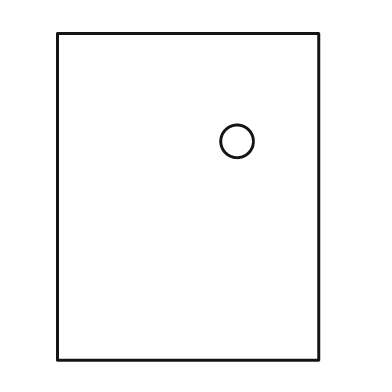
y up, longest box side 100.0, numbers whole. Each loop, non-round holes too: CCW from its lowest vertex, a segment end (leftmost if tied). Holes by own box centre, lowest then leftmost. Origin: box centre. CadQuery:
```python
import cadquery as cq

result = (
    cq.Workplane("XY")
    .moveTo(-40.0, -50.0)
    .lineTo(40.0, -50.0)
    .lineTo(40.0, 50.0)
    .lineTo(-40.0, 50.0)
    .close()
    .moveTo(15.0, 17.0)
    .circle(5.0)
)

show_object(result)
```